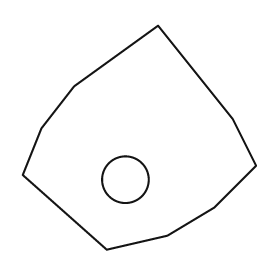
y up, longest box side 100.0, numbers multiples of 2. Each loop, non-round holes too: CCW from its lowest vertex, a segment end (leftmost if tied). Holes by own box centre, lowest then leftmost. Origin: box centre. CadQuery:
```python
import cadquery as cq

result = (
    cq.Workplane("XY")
    .moveTo(-14.0, -48.0)
    .lineTo(12.0, -42.0)
    .lineTo(32.0, -30.0)
    .lineTo(50.0, -12.0)
    .lineTo(40.0, 8.0)
    .lineTo(8.0, 48.0)
    .lineTo(-28.0, 22.0)
    .lineTo(-42.0, 4.0)
    .lineTo(-50.0, -16.0)
    .close()
    .moveTo(-6.0, -18.0)
    .circle(10.0)
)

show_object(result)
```